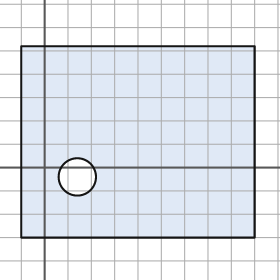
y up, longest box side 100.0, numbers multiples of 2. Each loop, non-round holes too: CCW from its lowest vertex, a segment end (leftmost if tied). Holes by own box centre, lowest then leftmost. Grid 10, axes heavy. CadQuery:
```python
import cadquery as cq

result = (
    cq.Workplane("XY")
    .moveTo(-10.0, -30.0)
    .lineTo(90.0, -30.0)
    .lineTo(90.0, 52.0)
    .lineTo(-10.0, 52.0)
    .close()
    .moveTo(14.0, -4.0)
    .circle(8.0)
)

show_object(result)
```